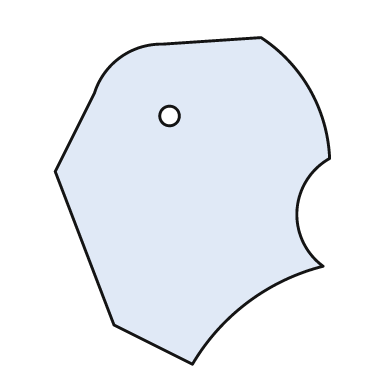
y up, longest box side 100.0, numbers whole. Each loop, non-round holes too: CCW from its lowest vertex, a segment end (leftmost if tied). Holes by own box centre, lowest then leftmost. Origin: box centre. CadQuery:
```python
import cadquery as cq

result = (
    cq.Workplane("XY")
    .moveTo(0.0, -50.0)
    .threePointArc((17.0, -31.0), (40.0, -20.0))
    .threePointArc((32.0, -3.0), (42.0, 13.0))
    .threePointArc((36.0, 34.0), (21.0, 50.0))
    .lineTo(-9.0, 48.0)
    .threePointArc((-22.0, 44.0), (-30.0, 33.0))
    .lineTo(-42.0, 9.0)
    .lineTo(-24.0, -38.0)
    .close()
    .moveTo(-7.0, 26.0)
    .circle(3.0)
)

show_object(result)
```